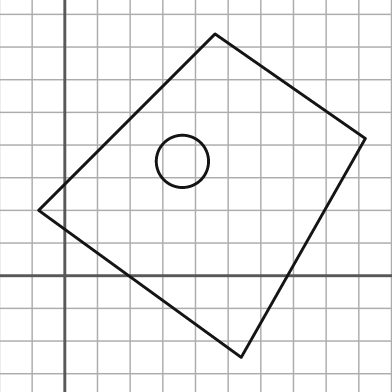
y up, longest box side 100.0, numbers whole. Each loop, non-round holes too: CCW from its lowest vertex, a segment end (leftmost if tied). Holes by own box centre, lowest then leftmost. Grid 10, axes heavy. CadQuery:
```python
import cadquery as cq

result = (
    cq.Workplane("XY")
    .moveTo(54.0, -25.0)
    .lineTo(92.0, 42.0)
    .lineTo(46.0, 74.0)
    .lineTo(-8.0, 20.0)
    .close()
    .moveTo(36.0, 35.0)
    .circle(8.0)
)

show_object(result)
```